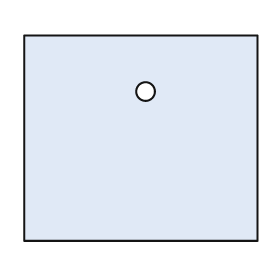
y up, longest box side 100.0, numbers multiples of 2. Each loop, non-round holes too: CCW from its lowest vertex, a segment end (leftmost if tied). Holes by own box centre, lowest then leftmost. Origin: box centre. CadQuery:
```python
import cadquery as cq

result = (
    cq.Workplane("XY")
    .moveTo(-50.0, -44.0)
    .lineTo(50.0, -44.0)
    .lineTo(50.0, 44.0)
    .lineTo(-50.0, 44.0)
    .close()
    .moveTo(2.0, 20.0)
    .circle(4.0)
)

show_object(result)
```